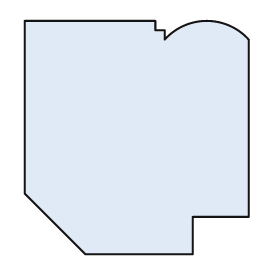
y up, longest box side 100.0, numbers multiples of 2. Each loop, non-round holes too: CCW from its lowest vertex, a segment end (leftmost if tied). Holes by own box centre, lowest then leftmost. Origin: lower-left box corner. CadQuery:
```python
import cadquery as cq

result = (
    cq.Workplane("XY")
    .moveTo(26.0, 0.0)
    .lineTo(72.0, 0.0)
    .lineTo(72.0, 16.0)
    .lineTo(96.0, 16.0)
    .lineTo(96.0, 92.0)
    .threePointArc((78.0, 100.0), (60.0, 92.0))
    .lineTo(60.0, 96.0)
    .lineTo(56.0, 96.0)
    .lineTo(56.0, 100.0)
    .lineTo(0.0, 100.0)
    .lineTo(0.0, 26.0)
    .close()
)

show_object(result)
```